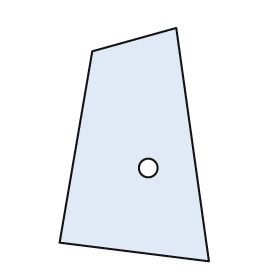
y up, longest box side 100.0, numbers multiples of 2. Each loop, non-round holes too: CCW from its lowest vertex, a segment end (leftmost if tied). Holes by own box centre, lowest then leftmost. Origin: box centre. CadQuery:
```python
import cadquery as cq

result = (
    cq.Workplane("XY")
    .moveTo(32.0, -50.0)
    .lineTo(18.0, 50.0)
    .lineTo(-18.0, 40.0)
    .lineTo(-32.0, -42.0)
    .close()
    .moveTo(6.0, -10.0)
    .circle(4.0)
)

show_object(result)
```